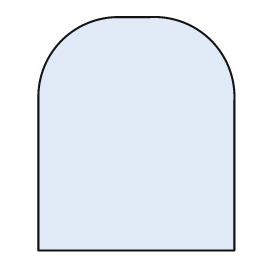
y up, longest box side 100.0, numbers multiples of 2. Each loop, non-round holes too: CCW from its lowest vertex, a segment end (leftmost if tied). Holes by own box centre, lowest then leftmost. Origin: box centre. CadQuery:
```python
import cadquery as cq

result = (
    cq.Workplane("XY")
    .moveTo(-42.0, -50.0)
    .lineTo(42.0, -50.0)
    .lineTo(42.0, 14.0)
    .threePointArc((32.0, 40.0), (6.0, 50.0))
    .lineTo(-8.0, 50.0)
    .threePointArc((-32.0, 40.0), (-42.0, 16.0))
    .close()
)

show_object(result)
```